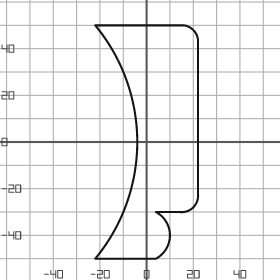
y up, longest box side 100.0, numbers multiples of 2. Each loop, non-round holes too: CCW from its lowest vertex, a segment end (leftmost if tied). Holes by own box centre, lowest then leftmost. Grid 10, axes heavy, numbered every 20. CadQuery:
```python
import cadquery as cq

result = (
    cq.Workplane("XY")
    .moveTo(-22.0, -50.0)
    .lineTo(4.0, -50.0)
    .threePointArc((10.0, -40.0), (4.0, -30.0))
    .lineTo(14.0, -30.0)
    .threePointArc((20.0, -28.0), (22.0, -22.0))
    .lineTo(22.0, 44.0)
    .threePointArc((20.0, 48.0), (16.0, 50.0))
    .lineTo(-22.0, 50.0)
    .threePointArc((-4.0, 0.0), (-22.0, -50.0))
    .close()
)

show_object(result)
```